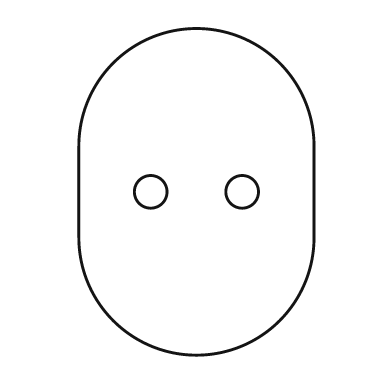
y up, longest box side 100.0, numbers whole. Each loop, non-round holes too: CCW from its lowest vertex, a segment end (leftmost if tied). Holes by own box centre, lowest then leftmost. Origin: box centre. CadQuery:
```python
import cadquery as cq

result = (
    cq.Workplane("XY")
    .moveTo(-36.0, -14.0)
    .threePointArc((0.0, -50.0), (36.0, -14.0))
    .lineTo(36.0, 14.0)
    .threePointArc((0.0, 50.0), (-36.0, 14.0))
    .close()
    .moveTo(-14.0, 0.0)
    .circle(5.0)
    .moveTo(14.0, 0.0)
    .circle(5.0)
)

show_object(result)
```